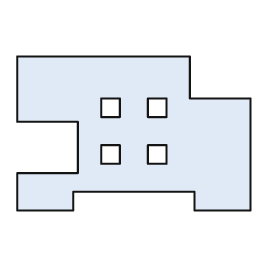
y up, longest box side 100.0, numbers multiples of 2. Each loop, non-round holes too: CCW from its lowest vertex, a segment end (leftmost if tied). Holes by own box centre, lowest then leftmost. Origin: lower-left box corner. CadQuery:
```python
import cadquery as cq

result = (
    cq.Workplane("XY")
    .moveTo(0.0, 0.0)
    .lineTo(24.0, 0.0)
    .lineTo(24.0, 8.0)
    .lineTo(76.0, 8.0)
    .lineTo(76.0, 0.0)
    .lineTo(100.0, 0.0)
    .lineTo(100.0, 48.0)
    .lineTo(74.0, 48.0)
    .lineTo(74.0, 66.0)
    .lineTo(0.0, 66.0)
    .lineTo(0.0, 38.0)
    .lineTo(26.0, 38.0)
    .lineTo(26.0, 16.0)
    .lineTo(0.0, 16.0)
    .close()
    .moveTo(36.0, 20.0)
    .lineTo(44.0, 20.0)
    .lineTo(44.0, 28.0)
    .lineTo(36.0, 28.0)
    .close()
    .moveTo(56.0, 20.0)
    .lineTo(64.0, 20.0)
    .lineTo(64.0, 28.0)
    .lineTo(56.0, 28.0)
    .close()
    .moveTo(36.0, 40.0)
    .lineTo(44.0, 40.0)
    .lineTo(44.0, 48.0)
    .lineTo(36.0, 48.0)
    .close()
    .moveTo(56.0, 40.0)
    .lineTo(64.0, 40.0)
    .lineTo(64.0, 48.0)
    .lineTo(56.0, 48.0)
    .close()
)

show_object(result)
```